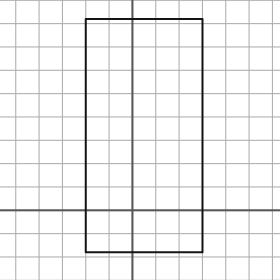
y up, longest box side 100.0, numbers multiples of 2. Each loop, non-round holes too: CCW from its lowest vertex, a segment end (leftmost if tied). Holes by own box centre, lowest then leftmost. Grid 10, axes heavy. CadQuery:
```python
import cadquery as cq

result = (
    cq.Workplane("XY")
    .moveTo(-20.0, -18.0)
    .lineTo(30.0, -18.0)
    .lineTo(30.0, 82.0)
    .lineTo(-20.0, 82.0)
    .close()
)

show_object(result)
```